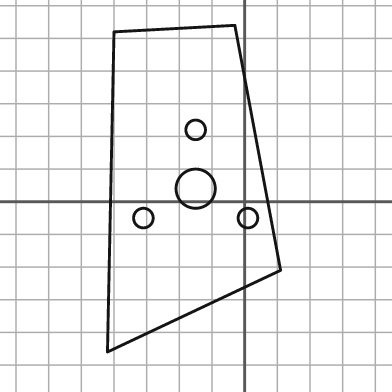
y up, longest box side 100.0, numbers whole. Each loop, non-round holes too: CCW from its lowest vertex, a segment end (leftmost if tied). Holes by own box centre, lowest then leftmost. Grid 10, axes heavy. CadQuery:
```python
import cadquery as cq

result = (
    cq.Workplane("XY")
    .moveTo(-42.0, -46.0)
    .lineTo(11.0, -21.0)
    .lineTo(-3.0, 54.0)
    .lineTo(-40.0, 52.0)
    .close()
    .moveTo(-31.0, -5.0)
    .circle(3.0)
    .moveTo(1.0, -5.0)
    .circle(3.0)
    .moveTo(-15.0, 4.0)
    .circle(6.0)
    .moveTo(-15.0, 22.0)
    .circle(3.0)
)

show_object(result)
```